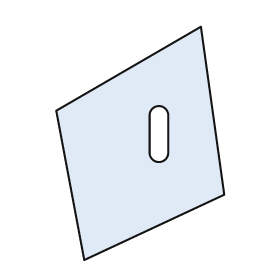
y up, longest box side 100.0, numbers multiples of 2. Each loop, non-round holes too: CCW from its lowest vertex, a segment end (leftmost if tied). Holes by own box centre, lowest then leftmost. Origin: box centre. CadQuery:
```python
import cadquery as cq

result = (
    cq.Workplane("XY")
    .moveTo(-24.0, -50.0)
    .lineTo(36.0, -22.0)
    .lineTo(26.0, 50.0)
    .lineTo(-36.0, 14.0)
    .close()
    .moveTo(4.0, -4.0)
    .threePointArc((8.0, -8.0), (12.0, -4.0))
    .lineTo(12.0, 12.0)
    .threePointArc((8.0, 16.0), (4.0, 12.0))
    .close()
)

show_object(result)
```